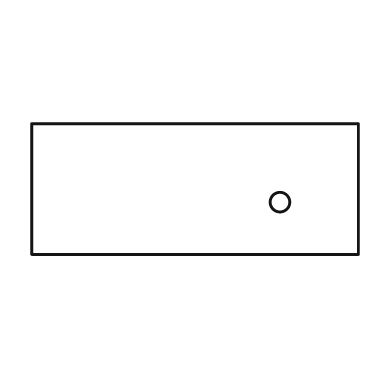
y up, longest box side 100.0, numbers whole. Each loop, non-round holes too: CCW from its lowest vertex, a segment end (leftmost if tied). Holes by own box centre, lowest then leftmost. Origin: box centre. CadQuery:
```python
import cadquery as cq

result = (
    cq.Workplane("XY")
    .moveTo(-50.0, -20.0)
    .lineTo(50.0, -20.0)
    .lineTo(50.0, 20.0)
    .lineTo(-50.0, 20.0)
    .close()
    .moveTo(26.0, -4.0)
    .circle(3.0)
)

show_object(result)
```